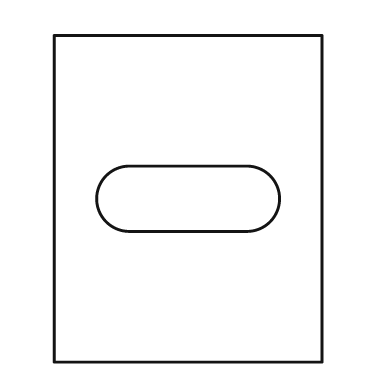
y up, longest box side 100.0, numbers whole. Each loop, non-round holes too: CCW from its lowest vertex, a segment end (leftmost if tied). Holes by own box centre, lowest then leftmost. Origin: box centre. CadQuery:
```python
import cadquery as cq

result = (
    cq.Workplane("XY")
    .moveTo(-41.0, -50.0)
    .lineTo(41.0, -50.0)
    .lineTo(41.0, 50.0)
    .lineTo(-41.0, 50.0)
    .close()
    .moveTo(-18.0, -10.0)
    .lineTo(18.0, -10.0)
    .threePointArc((28.0, 0.0), (18.0, 10.0))
    .lineTo(-18.0, 10.0)
    .threePointArc((-28.0, 0.0), (-18.0, -10.0))
    .close()
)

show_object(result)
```